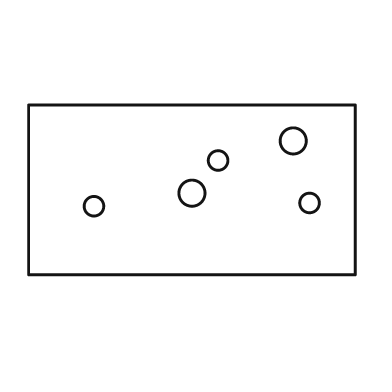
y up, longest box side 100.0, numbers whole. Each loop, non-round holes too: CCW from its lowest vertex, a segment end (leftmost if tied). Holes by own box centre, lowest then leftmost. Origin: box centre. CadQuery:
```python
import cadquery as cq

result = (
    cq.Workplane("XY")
    .moveTo(-50.0, -26.0)
    .lineTo(50.0, -26.0)
    .lineTo(50.0, 26.0)
    .lineTo(-50.0, 26.0)
    .close()
    .moveTo(-30.0, -5.0)
    .circle(3.0)
    .moveTo(36.0, -4.0)
    .circle(3.0)
    .moveTo(0.0, -1.0)
    .circle(4.0)
    .moveTo(8.0, 9.0)
    .circle(3.0)
    .moveTo(31.0, 15.0)
    .circle(4.0)
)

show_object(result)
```